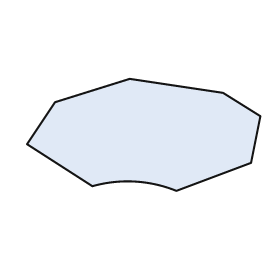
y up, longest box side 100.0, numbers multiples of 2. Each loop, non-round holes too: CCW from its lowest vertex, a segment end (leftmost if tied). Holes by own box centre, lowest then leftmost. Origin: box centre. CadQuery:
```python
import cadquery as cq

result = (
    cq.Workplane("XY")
    .moveTo(14.0, -24.0)
    .lineTo(46.0, -12.0)
    .lineTo(50.0, 8.0)
    .lineTo(34.0, 18.0)
    .lineTo(-6.0, 24.0)
    .lineTo(-38.0, 14.0)
    .lineTo(-50.0, -4.0)
    .lineTo(-22.0, -22.0)
    .threePointArc((-4.0, -20.0), (14.0, -24.0))
    .close()
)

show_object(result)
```